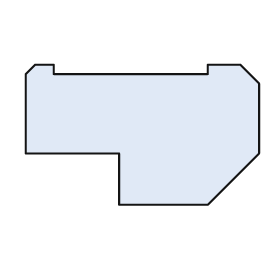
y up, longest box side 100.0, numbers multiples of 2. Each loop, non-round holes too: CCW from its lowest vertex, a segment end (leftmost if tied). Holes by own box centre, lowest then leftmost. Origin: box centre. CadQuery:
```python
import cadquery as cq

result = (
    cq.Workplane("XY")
    .moveTo(-10.0, -30.0)
    .lineTo(28.0, -30.0)
    .lineTo(50.0, -8.0)
    .lineTo(50.0, 22.0)
    .lineTo(42.0, 30.0)
    .lineTo(28.0, 30.0)
    .lineTo(28.0, 26.0)
    .lineTo(-38.0, 26.0)
    .lineTo(-38.0, 30.0)
    .lineTo(-46.0, 30.0)
    .lineTo(-50.0, 26.0)
    .lineTo(-50.0, -8.0)
    .lineTo(-10.0, -8.0)
    .close()
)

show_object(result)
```